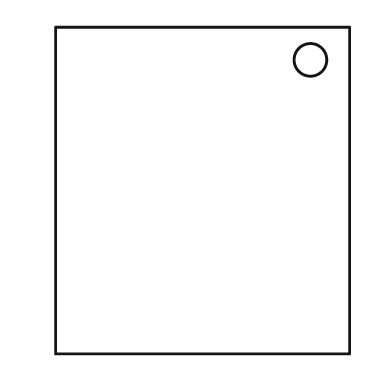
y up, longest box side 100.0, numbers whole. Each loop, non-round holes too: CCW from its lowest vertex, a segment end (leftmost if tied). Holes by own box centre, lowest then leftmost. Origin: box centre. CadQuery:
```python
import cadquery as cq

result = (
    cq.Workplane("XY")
    .moveTo(-45.0, -50.0)
    .lineTo(45.0, -50.0)
    .lineTo(45.0, 50.0)
    .lineTo(-45.0, 50.0)
    .close()
    .moveTo(33.0, 40.0)
    .circle(5.0)
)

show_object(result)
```